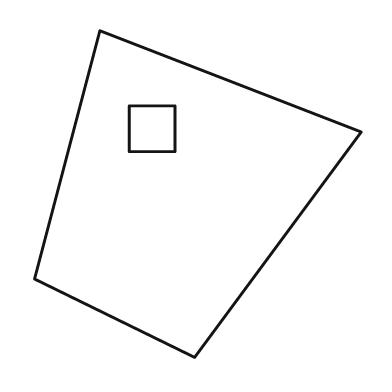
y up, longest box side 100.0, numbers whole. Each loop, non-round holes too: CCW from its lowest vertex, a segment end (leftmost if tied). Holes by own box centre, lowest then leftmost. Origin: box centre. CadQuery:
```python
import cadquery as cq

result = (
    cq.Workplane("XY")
    .moveTo(-1.0, -50.0)
    .lineTo(50.0, 19.0)
    .lineTo(-30.0, 50.0)
    .lineTo(-50.0, -26.0)
    .close()
    .moveTo(-21.0, 13.0)
    .lineTo(-7.0, 13.0)
    .lineTo(-7.0, 27.0)
    .lineTo(-21.0, 27.0)
    .close()
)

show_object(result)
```